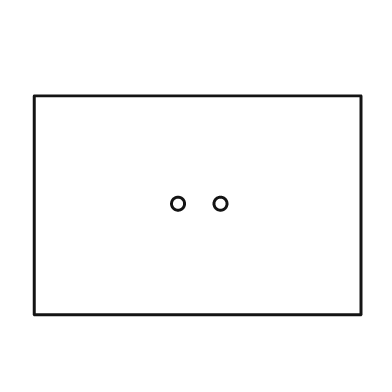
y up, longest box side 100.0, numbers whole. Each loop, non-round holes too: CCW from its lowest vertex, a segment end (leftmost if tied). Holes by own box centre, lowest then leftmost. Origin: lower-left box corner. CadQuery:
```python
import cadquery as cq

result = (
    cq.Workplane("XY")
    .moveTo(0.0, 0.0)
    .lineTo(100.0, 0.0)
    .lineTo(100.0, 67.0)
    .lineTo(0.0, 67.0)
    .close()
    .moveTo(44.0, 34.0)
    .circle(2.0)
    .moveTo(57.0, 34.0)
    .circle(2.0)
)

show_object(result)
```